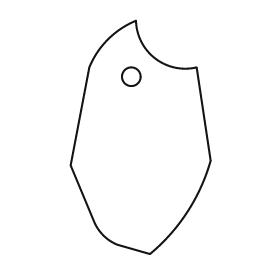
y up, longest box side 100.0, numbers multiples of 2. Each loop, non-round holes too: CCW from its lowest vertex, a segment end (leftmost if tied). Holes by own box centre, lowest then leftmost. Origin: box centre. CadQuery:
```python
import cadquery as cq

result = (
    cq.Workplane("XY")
    .moveTo(4.0, -50.0)
    .threePointArc((20.0, -32.0), (30.0, -10.0))
    .lineTo(24.0, 30.0)
    .threePointArc((6.0, 34.0), (-2.0, 50.0))
    .threePointArc((-14.0, 42.0), (-22.0, 30.0))
    .lineTo(-30.0, -12.0)
    .lineTo(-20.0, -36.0)
    .threePointArc((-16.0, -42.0), (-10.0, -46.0))
    .close()
    .moveTo(-4.0, 26.0)
    .circle(4.0)
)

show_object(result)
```